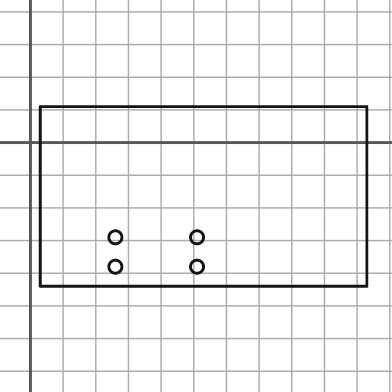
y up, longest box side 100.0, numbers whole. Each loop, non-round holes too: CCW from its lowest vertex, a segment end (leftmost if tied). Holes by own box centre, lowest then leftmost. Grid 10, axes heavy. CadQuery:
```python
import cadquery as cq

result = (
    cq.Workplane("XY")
    .moveTo(3.0, -44.0)
    .lineTo(103.0, -44.0)
    .lineTo(103.0, 11.0)
    .lineTo(3.0, 11.0)
    .close()
    .moveTo(26.0, -38.0)
    .circle(2.0)
    .moveTo(51.0, -38.0)
    .circle(2.0)
    .moveTo(26.0, -29.0)
    .circle(2.0)
    .moveTo(51.0, -29.0)
    .circle(2.0)
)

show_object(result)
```